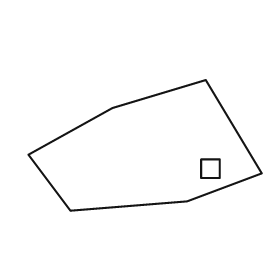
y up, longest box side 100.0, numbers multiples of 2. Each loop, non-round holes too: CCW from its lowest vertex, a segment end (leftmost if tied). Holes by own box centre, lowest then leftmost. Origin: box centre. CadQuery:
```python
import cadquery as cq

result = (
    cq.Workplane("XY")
    .moveTo(-32.0, -28.0)
    .lineTo(18.0, -24.0)
    .lineTo(50.0, -12.0)
    .lineTo(26.0, 28.0)
    .lineTo(-14.0, 16.0)
    .lineTo(-50.0, -4.0)
    .close()
    .moveTo(24.0, -14.0)
    .lineTo(32.0, -14.0)
    .lineTo(32.0, -6.0)
    .lineTo(24.0, -6.0)
    .close()
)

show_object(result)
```